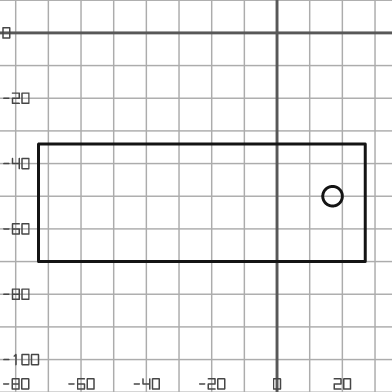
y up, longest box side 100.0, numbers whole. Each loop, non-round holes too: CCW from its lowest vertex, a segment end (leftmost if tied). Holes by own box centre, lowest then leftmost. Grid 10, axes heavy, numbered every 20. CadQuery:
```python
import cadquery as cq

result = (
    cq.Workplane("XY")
    .moveTo(-73.0, -70.0)
    .lineTo(27.0, -70.0)
    .lineTo(27.0, -34.0)
    .lineTo(-73.0, -34.0)
    .close()
    .moveTo(17.0, -50.0)
    .circle(3.0)
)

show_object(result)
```